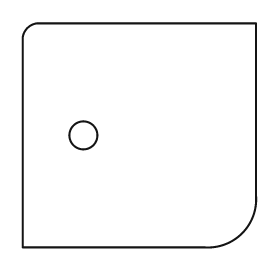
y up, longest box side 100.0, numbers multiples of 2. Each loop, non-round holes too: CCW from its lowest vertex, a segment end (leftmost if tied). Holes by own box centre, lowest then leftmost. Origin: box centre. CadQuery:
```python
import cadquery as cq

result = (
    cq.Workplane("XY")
    .moveTo(-50.0, -48.0)
    .lineTo(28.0, -48.0)
    .threePointArc((44.0, -42.0), (50.0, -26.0))
    .lineTo(50.0, 48.0)
    .lineTo(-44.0, 48.0)
    .threePointArc((-48.0, 46.0), (-50.0, 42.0))
    .close()
    .moveTo(-24.0, 0.0)
    .circle(6.0)
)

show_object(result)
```